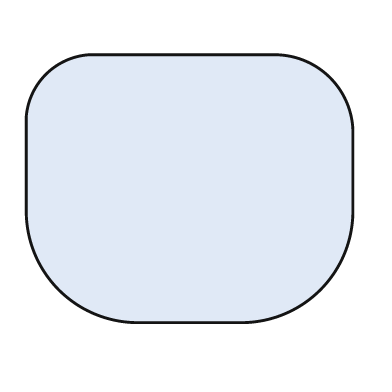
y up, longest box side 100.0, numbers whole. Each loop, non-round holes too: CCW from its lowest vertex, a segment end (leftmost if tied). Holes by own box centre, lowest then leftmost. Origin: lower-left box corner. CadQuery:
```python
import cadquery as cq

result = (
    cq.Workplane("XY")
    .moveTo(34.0, 0.0)
    .lineTo(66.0, 0.0)
    .threePointArc((90.0, 10.0), (100.0, 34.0))
    .lineTo(100.0, 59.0)
    .threePointArc((93.0, 75.0), (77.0, 82.0))
    .lineTo(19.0, 82.0)
    .threePointArc((6.0, 76.0), (0.0, 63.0))
    .lineTo(0.0, 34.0)
    .threePointArc((10.0, 10.0), (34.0, 0.0))
    .close()
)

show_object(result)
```